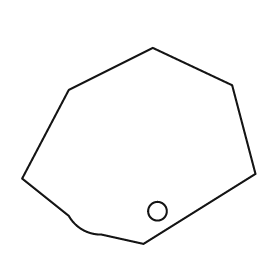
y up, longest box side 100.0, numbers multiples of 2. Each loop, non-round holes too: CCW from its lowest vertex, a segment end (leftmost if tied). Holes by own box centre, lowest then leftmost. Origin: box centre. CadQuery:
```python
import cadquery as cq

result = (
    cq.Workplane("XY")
    .moveTo(2.0, -42.0)
    .lineTo(50.0, -12.0)
    .lineTo(40.0, 26.0)
    .lineTo(6.0, 42.0)
    .lineTo(-30.0, 24.0)
    .lineTo(-50.0, -14.0)
    .lineTo(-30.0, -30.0)
    .threePointArc((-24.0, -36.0), (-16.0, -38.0))
    .close()
    .moveTo(8.0, -28.0)
    .circle(4.0)
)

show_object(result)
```